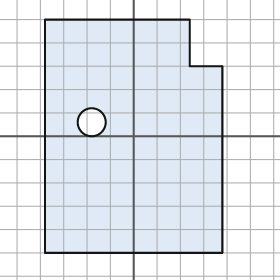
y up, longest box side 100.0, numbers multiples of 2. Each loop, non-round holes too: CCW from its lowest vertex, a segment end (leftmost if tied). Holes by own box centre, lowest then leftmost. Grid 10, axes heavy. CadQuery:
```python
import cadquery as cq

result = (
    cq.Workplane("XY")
    .moveTo(-38.0, -50.0)
    .lineTo(38.0, -50.0)
    .lineTo(38.0, 30.0)
    .lineTo(24.0, 30.0)
    .lineTo(24.0, 50.0)
    .lineTo(-38.0, 50.0)
    .close()
    .moveTo(-18.0, 6.0)
    .circle(6.0)
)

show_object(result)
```